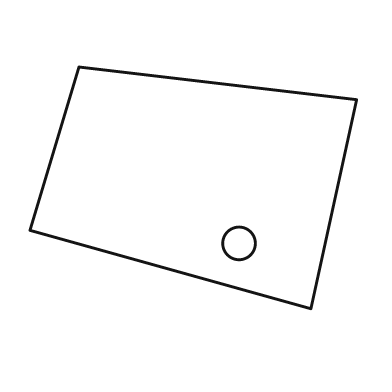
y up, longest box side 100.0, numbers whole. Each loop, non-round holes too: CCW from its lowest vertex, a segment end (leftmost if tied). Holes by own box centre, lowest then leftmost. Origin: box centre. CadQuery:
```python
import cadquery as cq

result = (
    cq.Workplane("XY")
    .moveTo(36.0, -37.0)
    .lineTo(50.0, 27.0)
    .lineTo(-35.0, 37.0)
    .lineTo(-50.0, -13.0)
    .close()
    .moveTo(14.0, -17.0)
    .circle(5.0)
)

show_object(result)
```